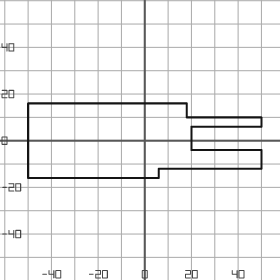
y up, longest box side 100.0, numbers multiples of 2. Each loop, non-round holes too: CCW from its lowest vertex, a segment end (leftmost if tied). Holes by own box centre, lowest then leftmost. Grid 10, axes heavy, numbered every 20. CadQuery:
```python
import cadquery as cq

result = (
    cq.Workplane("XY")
    .moveTo(-50.0, -16.0)
    .lineTo(6.0, -16.0)
    .lineTo(6.0, -12.0)
    .lineTo(50.0, -12.0)
    .lineTo(50.0, -4.0)
    .lineTo(20.0, -4.0)
    .lineTo(20.0, 6.0)
    .lineTo(50.0, 6.0)
    .lineTo(50.0, 10.0)
    .lineTo(18.0, 10.0)
    .lineTo(18.0, 16.0)
    .lineTo(-50.0, 16.0)
    .close()
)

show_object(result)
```